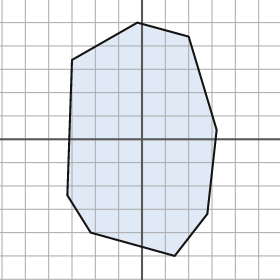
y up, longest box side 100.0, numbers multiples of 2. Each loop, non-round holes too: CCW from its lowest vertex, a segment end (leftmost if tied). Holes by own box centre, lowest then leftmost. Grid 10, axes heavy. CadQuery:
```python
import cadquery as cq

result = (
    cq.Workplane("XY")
    .moveTo(14.0, -50.0)
    .lineTo(28.0, -32.0)
    .lineTo(32.0, 4.0)
    .lineTo(20.0, 44.0)
    .lineTo(-2.0, 50.0)
    .lineTo(-30.0, 34.0)
    .lineTo(-32.0, -24.0)
    .lineTo(-22.0, -40.0)
    .close()
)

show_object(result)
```